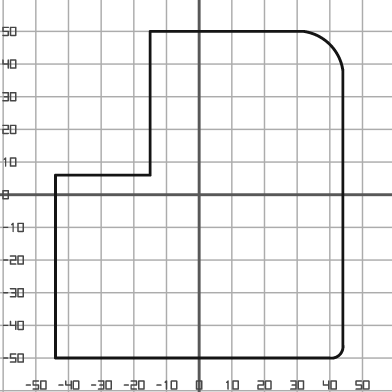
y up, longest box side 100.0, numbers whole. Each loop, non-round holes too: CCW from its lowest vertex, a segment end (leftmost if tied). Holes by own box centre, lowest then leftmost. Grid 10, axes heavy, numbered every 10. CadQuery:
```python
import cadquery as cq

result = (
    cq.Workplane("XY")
    .moveTo(-44.0, -50.0)
    .lineTo(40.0, -50.0)
    .threePointArc((43.0, -49.0), (44.0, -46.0))
    .lineTo(44.0, 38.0)
    .threePointArc((40.0, 46.0), (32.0, 50.0))
    .lineTo(-15.0, 50.0)
    .lineTo(-15.0, 6.0)
    .lineTo(-44.0, 6.0)
    .close()
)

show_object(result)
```